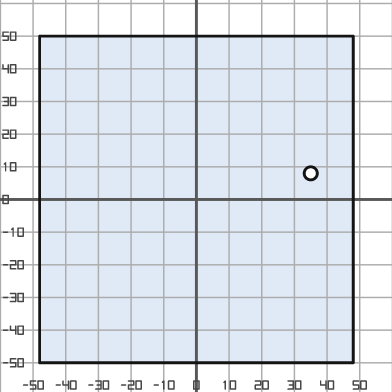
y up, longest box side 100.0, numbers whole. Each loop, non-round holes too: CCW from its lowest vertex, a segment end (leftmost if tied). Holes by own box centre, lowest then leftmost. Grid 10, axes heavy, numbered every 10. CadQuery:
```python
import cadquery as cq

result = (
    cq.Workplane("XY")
    .moveTo(-48.0, -50.0)
    .lineTo(48.0, -50.0)
    .lineTo(48.0, 50.0)
    .lineTo(-48.0, 50.0)
    .close()
    .moveTo(35.0, 8.0)
    .circle(2.0)
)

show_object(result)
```